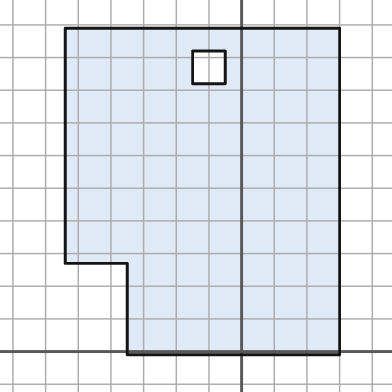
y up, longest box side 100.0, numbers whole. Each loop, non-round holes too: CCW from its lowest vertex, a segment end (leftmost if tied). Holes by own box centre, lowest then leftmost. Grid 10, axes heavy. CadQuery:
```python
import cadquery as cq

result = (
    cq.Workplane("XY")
    .moveTo(-35.0, -1.0)
    .lineTo(30.0, -1.0)
    .lineTo(30.0, 99.0)
    .lineTo(-54.0, 99.0)
    .lineTo(-54.0, 27.0)
    .lineTo(-35.0, 27.0)
    .close()
    .moveTo(-15.0, 82.0)
    .lineTo(-5.0, 82.0)
    .lineTo(-5.0, 92.0)
    .lineTo(-15.0, 92.0)
    .close()
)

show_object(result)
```